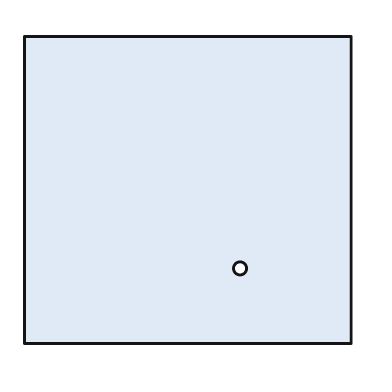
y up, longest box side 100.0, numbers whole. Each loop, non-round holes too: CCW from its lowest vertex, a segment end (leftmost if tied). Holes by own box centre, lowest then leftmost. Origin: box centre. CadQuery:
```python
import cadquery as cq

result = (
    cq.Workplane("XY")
    .moveTo(-50.0, -47.0)
    .lineTo(50.0, -47.0)
    .lineTo(50.0, 47.0)
    .lineTo(-50.0, 47.0)
    .close()
    .moveTo(16.0, -24.0)
    .circle(2.0)
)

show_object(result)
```